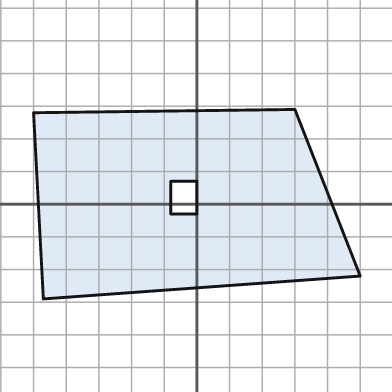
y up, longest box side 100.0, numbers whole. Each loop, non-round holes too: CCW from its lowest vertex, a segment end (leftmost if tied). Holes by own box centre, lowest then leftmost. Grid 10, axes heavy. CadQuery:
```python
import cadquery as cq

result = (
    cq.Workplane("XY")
    .moveTo(-47.0, -29.0)
    .lineTo(50.0, -22.0)
    .lineTo(30.0, 29.0)
    .lineTo(-50.0, 28.0)
    .close()
    .moveTo(-8.0, -3.0)
    .lineTo(0.0, -3.0)
    .lineTo(0.0, 7.0)
    .lineTo(-8.0, 7.0)
    .close()
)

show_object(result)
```